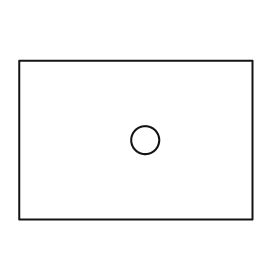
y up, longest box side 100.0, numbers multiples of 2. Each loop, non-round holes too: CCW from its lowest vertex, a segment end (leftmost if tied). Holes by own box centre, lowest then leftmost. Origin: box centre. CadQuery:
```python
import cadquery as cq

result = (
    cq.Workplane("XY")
    .moveTo(-50.0, -34.0)
    .lineTo(50.0, -34.0)
    .lineTo(50.0, 34.0)
    .lineTo(-50.0, 34.0)
    .close()
    .moveTo(4.0, 0.0)
    .circle(6.0)
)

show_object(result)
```